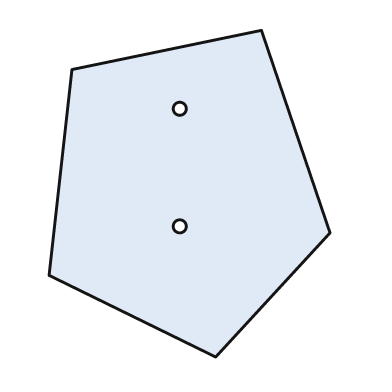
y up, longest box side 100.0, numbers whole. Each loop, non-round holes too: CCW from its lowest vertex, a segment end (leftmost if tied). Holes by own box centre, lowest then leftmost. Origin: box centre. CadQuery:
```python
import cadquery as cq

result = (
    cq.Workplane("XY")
    .moveTo(8.0, -50.0)
    .lineTo(43.0, -12.0)
    .lineTo(22.0, 50.0)
    .lineTo(-36.0, 38.0)
    .lineTo(-43.0, -25.0)
    .close()
    .moveTo(-3.0, -10.0)
    .circle(2.0)
    .moveTo(-3.0, 26.0)
    .circle(2.0)
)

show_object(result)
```